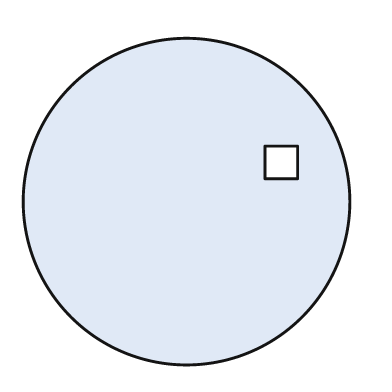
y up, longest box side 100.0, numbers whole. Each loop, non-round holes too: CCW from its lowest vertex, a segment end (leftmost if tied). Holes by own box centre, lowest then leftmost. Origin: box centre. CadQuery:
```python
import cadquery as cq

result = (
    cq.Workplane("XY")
    .moveTo(0.0, 0.0)
    .circle(50.0)
    .moveTo(24.0, 7.0)
    .lineTo(34.0, 7.0)
    .lineTo(34.0, 17.0)
    .lineTo(24.0, 17.0)
    .close()
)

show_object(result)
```